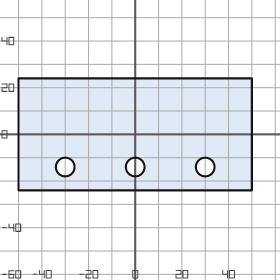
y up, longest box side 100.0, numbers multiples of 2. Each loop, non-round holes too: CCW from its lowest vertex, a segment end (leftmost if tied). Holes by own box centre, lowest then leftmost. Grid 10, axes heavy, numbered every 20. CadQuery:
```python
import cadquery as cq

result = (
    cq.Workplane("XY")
    .moveTo(-50.0, -24.0)
    .lineTo(50.0, -24.0)
    .lineTo(50.0, 24.0)
    .lineTo(-50.0, 24.0)
    .close()
    .moveTo(-30.0, -14.0)
    .circle(4.0)
    .moveTo(0.0, -14.0)
    .circle(4.0)
    .moveTo(30.0, -14.0)
    .circle(4.0)
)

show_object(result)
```